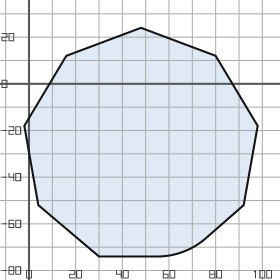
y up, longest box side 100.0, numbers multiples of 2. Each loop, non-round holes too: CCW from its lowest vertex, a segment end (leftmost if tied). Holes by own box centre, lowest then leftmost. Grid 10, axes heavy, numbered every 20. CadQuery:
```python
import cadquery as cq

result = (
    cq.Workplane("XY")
    .moveTo(30.0, -74.0)
    .lineTo(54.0, -74.0)
    .threePointArc((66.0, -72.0), (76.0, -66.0))
    .lineTo(92.0, -52.0)
    .lineTo(98.0, -18.0)
    .lineTo(80.0, 12.0)
    .lineTo(48.0, 24.0)
    .lineTo(16.0, 12.0)
    .lineTo(-2.0, -18.0)
    .lineTo(4.0, -52.0)
    .close()
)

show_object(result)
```